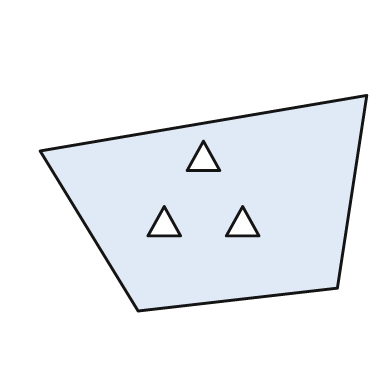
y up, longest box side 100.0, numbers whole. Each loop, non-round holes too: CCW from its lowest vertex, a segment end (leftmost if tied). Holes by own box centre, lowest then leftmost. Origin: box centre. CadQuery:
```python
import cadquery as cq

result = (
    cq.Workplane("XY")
    .moveTo(-20.0, -33.0)
    .lineTo(41.0, -26.0)
    .lineTo(50.0, 33.0)
    .lineTo(-50.0, 16.0)
    .close()
    .moveTo(-17.0, -10.0)
    .lineTo(-7.0, -10.0)
    .lineTo(-12.0, -1.0)
    .close()
    .moveTo(7.0, -10.0)
    .lineTo(17.0, -10.0)
    .lineTo(12.0, -1.0)
    .close()
    .moveTo(-5.0, 10.0)
    .lineTo(5.0, 10.0)
    .lineTo(0.0, 19.0)
    .close()
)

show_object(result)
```